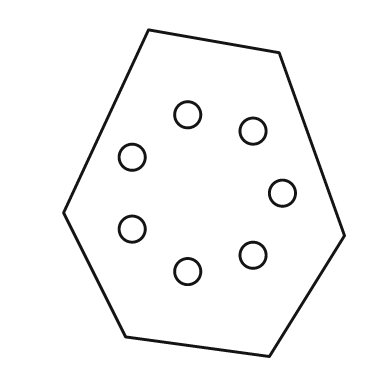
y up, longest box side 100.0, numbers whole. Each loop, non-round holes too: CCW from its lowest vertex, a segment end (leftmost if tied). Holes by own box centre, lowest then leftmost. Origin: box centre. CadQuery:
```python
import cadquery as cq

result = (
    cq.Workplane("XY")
    .moveTo(20.0, -50.0)
    .lineTo(43.0, -13.0)
    .lineTo(23.0, 43.0)
    .lineTo(-17.0, 50.0)
    .lineTo(-43.0, -6.0)
    .lineTo(-24.0, -44.0)
    .close()
    .moveTo(-5.0, -24.0)
    .circle(4.0)
    .moveTo(15.0, -19.0)
    .circle(4.0)
    .moveTo(-22.0, -11.0)
    .circle(4.0)
    .moveTo(24.0, 0.0)
    .circle(4.0)
    .moveTo(-22.0, 11.0)
    .circle(4.0)
    .moveTo(15.0, 19.0)
    .circle(4.0)
    .moveTo(-5.0, 24.0)
    .circle(4.0)
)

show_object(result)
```